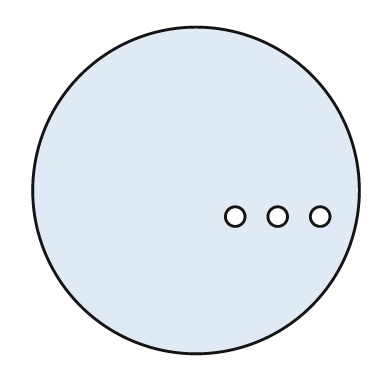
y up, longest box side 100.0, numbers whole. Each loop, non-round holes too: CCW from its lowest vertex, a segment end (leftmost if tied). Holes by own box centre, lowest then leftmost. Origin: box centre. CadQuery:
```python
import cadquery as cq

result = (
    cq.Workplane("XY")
    .moveTo(0.0, 0.0)
    .circle(50.0)
    .moveTo(12.0, -8.0)
    .circle(3.0)
    .moveTo(25.0, -8.0)
    .circle(3.0)
    .moveTo(38.0, -8.0)
    .circle(3.0)
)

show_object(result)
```